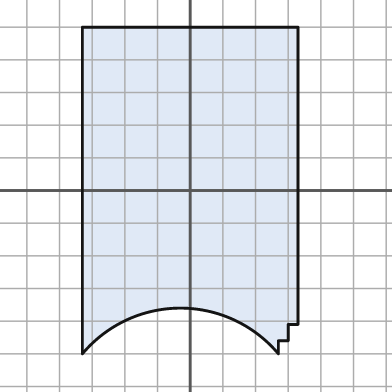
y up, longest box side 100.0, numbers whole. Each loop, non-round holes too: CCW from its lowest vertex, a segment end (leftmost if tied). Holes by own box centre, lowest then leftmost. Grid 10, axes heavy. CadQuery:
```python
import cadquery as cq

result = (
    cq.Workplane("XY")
    .moveTo(-33.0, -50.0)
    .threePointArc((-3.0, -36.0), (27.0, -50.0))
    .lineTo(27.0, -46.0)
    .lineTo(30.0, -46.0)
    .lineTo(30.0, -41.0)
    .lineTo(33.0, -41.0)
    .lineTo(33.0, 50.0)
    .lineTo(-33.0, 50.0)
    .close()
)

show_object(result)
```